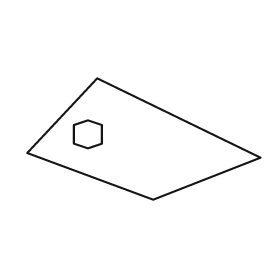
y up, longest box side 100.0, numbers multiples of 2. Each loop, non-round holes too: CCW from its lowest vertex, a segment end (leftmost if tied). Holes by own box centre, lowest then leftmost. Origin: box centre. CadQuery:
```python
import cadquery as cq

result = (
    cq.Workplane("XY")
    .moveTo(4.0, -26.0)
    .lineTo(50.0, -8.0)
    .lineTo(-20.0, 26.0)
    .lineTo(-50.0, -6.0)
    .close()
    .moveTo(-24.0, -4.0)
    .lineTo(-18.0, -2.0)
    .lineTo(-18.0, 6.0)
    .lineTo(-24.0, 8.0)
    .lineTo(-30.0, 6.0)
    .lineTo(-30.0, -2.0)
    .close()
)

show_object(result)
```